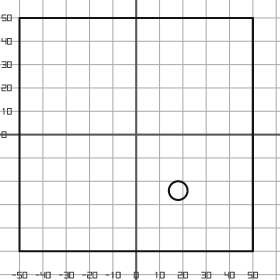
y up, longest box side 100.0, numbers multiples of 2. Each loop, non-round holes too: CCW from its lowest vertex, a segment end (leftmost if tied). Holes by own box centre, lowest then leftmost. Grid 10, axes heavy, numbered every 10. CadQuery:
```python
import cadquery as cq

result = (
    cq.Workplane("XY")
    .moveTo(-50.0, -50.0)
    .lineTo(50.0, -50.0)
    .lineTo(50.0, 50.0)
    .lineTo(-50.0, 50.0)
    .close()
    .moveTo(18.0, -24.0)
    .circle(4.0)
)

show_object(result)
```